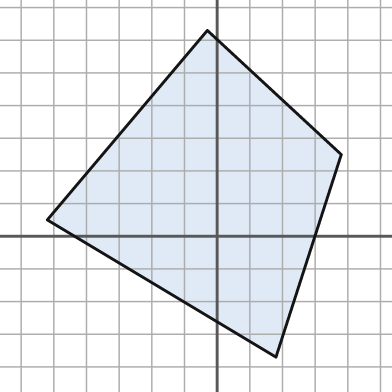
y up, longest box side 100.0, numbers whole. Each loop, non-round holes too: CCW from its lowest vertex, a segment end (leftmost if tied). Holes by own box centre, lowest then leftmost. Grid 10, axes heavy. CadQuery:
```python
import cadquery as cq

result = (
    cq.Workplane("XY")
    .moveTo(18.0, -37.0)
    .lineTo(38.0, 25.0)
    .lineTo(-3.0, 63.0)
    .lineTo(-52.0, 5.0)
    .close()
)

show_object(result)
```